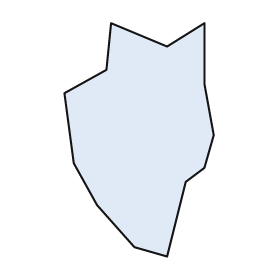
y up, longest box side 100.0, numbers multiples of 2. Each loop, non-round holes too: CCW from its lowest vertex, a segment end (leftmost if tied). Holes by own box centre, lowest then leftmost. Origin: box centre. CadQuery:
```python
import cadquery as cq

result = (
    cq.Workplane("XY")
    .moveTo(12.0, -50.0)
    .lineTo(20.0, -18.0)
    .lineTo(28.0, -12.0)
    .lineTo(32.0, 2.0)
    .lineTo(28.0, 24.0)
    .lineTo(28.0, 50.0)
    .lineTo(12.0, 40.0)
    .lineTo(-12.0, 50.0)
    .lineTo(-14.0, 30.0)
    .lineTo(-32.0, 20.0)
    .lineTo(-28.0, -10.0)
    .lineTo(-18.0, -28.0)
    .lineTo(-2.0, -46.0)
    .close()
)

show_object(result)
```